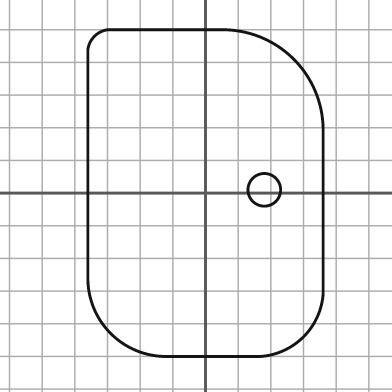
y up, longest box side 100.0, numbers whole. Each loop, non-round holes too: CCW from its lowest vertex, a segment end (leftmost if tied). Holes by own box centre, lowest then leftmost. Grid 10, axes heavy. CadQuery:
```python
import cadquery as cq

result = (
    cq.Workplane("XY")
    .moveTo(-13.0, -50.0)
    .lineTo(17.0, -50.0)
    .threePointArc((30.0, -44.0), (36.0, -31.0))
    .lineTo(36.0, 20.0)
    .threePointArc((27.0, 41.0), (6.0, 50.0))
    .lineTo(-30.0, 50.0)
    .threePointArc((-34.0, 48.0), (-36.0, 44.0))
    .lineTo(-36.0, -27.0)
    .threePointArc((-29.0, -43.0), (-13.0, -50.0))
    .close()
    .moveTo(18.0, 1.0)
    .circle(5.0)
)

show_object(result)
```